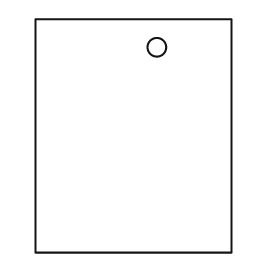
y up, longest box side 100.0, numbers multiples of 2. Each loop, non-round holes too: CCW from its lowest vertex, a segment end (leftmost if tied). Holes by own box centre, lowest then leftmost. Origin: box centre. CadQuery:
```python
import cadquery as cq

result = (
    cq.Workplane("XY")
    .moveTo(-42.0, -50.0)
    .lineTo(42.0, -50.0)
    .lineTo(42.0, 50.0)
    .lineTo(-42.0, 50.0)
    .close()
    .moveTo(10.0, 38.0)
    .circle(4.0)
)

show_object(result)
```